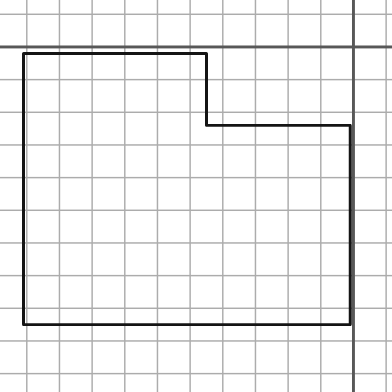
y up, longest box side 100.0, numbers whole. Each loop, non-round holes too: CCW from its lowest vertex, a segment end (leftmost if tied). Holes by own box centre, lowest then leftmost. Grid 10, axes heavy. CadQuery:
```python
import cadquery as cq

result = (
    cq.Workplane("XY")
    .moveTo(-101.0, -85.0)
    .lineTo(-1.0, -85.0)
    .lineTo(-1.0, -24.0)
    .lineTo(-45.0, -24.0)
    .lineTo(-45.0, -2.0)
    .lineTo(-101.0, -2.0)
    .close()
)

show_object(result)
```